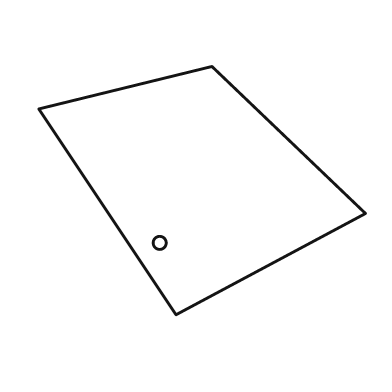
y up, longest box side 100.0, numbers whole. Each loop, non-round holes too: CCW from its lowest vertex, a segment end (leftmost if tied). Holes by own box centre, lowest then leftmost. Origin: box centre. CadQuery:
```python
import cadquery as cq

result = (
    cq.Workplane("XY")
    .moveTo(-8.0, -38.0)
    .lineTo(50.0, -7.0)
    .lineTo(3.0, 38.0)
    .lineTo(-50.0, 25.0)
    .close()
    .moveTo(-13.0, -16.0)
    .circle(2.0)
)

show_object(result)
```